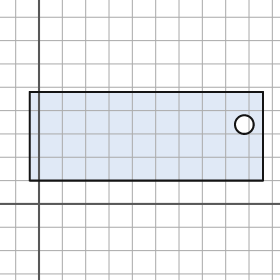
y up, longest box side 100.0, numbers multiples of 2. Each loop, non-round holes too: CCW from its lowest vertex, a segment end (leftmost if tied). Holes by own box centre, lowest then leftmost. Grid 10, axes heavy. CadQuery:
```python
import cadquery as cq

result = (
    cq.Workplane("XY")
    .moveTo(-4.0, 10.0)
    .lineTo(96.0, 10.0)
    .lineTo(96.0, 48.0)
    .lineTo(-4.0, 48.0)
    .close()
    .moveTo(88.0, 34.0)
    .circle(4.0)
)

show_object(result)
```